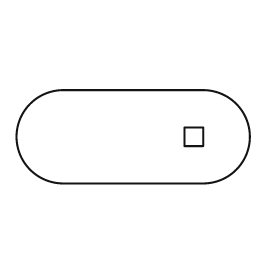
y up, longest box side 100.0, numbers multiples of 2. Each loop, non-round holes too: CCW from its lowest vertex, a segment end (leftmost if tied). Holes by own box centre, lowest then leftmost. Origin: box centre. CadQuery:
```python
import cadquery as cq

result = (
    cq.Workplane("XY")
    .moveTo(-30.0, -20.0)
    .lineTo(30.0, -20.0)
    .threePointArc((50.0, 0.0), (30.0, 20.0))
    .lineTo(-30.0, 20.0)
    .threePointArc((-50.0, 0.0), (-30.0, -20.0))
    .close()
    .moveTo(22.0, -4.0)
    .lineTo(30.0, -4.0)
    .lineTo(30.0, 4.0)
    .lineTo(22.0, 4.0)
    .close()
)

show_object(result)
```